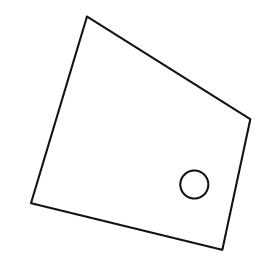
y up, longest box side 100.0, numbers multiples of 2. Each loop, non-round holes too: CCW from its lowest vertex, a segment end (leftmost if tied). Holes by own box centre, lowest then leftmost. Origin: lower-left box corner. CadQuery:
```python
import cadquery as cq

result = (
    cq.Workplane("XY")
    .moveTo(82.0, 0.0)
    .lineTo(94.0, 56.0)
    .lineTo(24.0, 100.0)
    .lineTo(0.0, 20.0)
    .close()
    .moveTo(70.0, 28.0)
    .circle(6.0)
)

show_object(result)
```